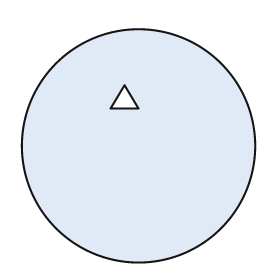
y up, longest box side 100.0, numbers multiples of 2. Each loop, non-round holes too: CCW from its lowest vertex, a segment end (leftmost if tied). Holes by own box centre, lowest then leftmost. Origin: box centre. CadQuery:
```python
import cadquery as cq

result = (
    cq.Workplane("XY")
    .moveTo(0.0, 0.0)
    .circle(50.0)
    .moveTo(-12.0, 16.0)
    .lineTo(0.0, 16.0)
    .lineTo(-6.0, 26.0)
    .close()
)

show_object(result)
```